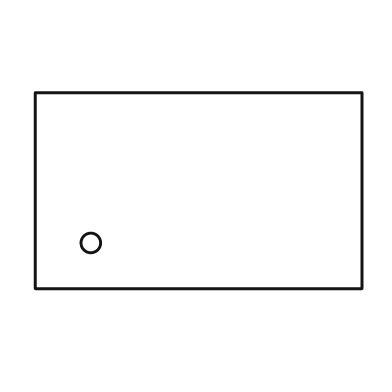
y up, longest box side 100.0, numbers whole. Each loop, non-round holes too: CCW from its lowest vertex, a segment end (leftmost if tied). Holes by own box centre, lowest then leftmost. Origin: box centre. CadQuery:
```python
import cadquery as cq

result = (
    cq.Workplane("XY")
    .moveTo(-50.0, -30.0)
    .lineTo(50.0, -30.0)
    .lineTo(50.0, 30.0)
    .lineTo(-50.0, 30.0)
    .close()
    .moveTo(-33.0, -16.0)
    .circle(3.0)
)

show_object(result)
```